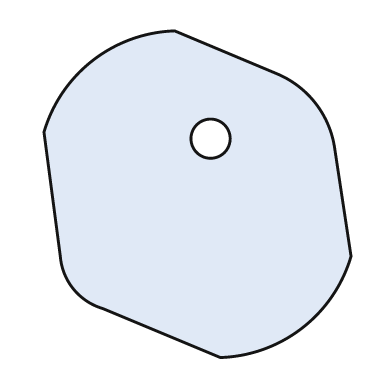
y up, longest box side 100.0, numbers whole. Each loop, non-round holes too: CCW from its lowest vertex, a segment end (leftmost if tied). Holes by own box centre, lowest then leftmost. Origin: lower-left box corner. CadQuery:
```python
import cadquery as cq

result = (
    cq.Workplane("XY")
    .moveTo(54.0, 0.0)
    .threePointArc((79.0, 9.0), (94.0, 31.0))
    .lineTo(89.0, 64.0)
    .threePointArc((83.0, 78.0), (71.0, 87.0))
    .lineTo(40.0, 100.0)
    .threePointArc((15.0, 91.0), (0.0, 69.0))
    .lineTo(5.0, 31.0)
    .threePointArc((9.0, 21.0), (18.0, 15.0))
    .close()
    .moveTo(51.0, 67.0)
    .circle(6.0)
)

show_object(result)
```